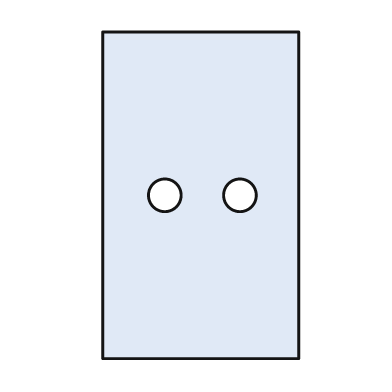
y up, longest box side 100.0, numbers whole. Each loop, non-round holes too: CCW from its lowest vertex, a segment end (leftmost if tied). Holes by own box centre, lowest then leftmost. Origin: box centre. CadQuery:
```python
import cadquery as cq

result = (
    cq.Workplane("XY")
    .moveTo(-30.0, -50.0)
    .lineTo(30.0, -50.0)
    .lineTo(30.0, 50.0)
    .lineTo(-30.0, 50.0)
    .close()
    .moveTo(-11.0, 0.0)
    .circle(5.0)
    .moveTo(12.0, 0.0)
    .circle(5.0)
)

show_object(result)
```